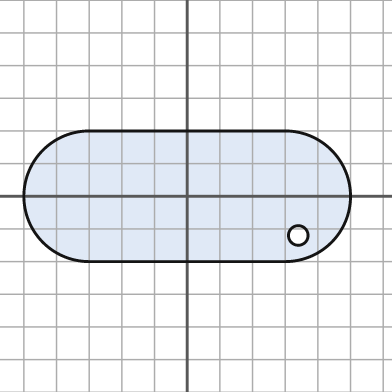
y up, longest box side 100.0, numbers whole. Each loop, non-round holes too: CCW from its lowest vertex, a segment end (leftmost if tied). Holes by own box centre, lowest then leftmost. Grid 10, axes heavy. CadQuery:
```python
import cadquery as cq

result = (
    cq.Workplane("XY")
    .moveTo(-30.0, -20.0)
    .lineTo(30.0, -20.0)
    .threePointArc((50.0, 0.0), (30.0, 20.0))
    .lineTo(-30.0, 20.0)
    .threePointArc((-50.0, 0.0), (-30.0, -20.0))
    .close()
    .moveTo(34.0, -12.0)
    .circle(3.0)
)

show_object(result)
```